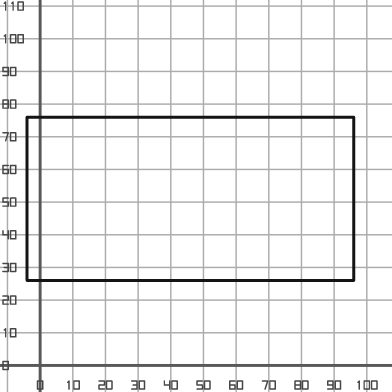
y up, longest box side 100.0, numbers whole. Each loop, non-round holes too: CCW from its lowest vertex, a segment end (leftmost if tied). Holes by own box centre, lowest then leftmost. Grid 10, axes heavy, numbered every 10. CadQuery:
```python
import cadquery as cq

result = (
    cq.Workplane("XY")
    .moveTo(-4.0, 26.0)
    .lineTo(96.0, 26.0)
    .lineTo(96.0, 76.0)
    .lineTo(-4.0, 76.0)
    .close()
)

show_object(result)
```